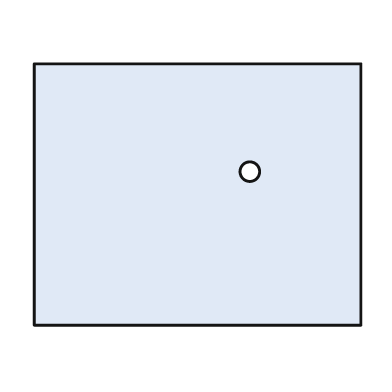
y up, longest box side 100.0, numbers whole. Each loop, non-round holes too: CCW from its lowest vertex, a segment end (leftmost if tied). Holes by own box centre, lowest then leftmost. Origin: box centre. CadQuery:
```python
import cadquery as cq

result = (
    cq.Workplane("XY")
    .moveTo(-50.0, -40.0)
    .lineTo(50.0, -40.0)
    .lineTo(50.0, 40.0)
    .lineTo(-50.0, 40.0)
    .close()
    .moveTo(16.0, 7.0)
    .circle(3.0)
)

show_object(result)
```